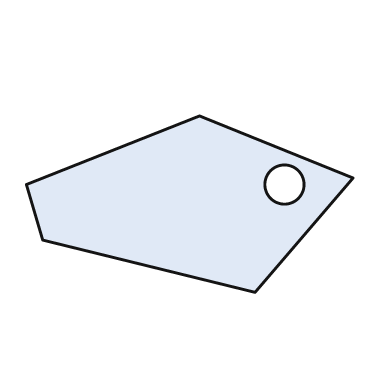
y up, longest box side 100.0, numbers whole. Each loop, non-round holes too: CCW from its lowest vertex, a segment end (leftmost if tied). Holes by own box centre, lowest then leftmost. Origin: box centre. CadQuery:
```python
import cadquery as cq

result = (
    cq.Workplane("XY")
    .moveTo(20.0, -27.0)
    .lineTo(50.0, 8.0)
    .lineTo(3.0, 27.0)
    .lineTo(-50.0, 6.0)
    .lineTo(-45.0, -11.0)
    .close()
    .moveTo(29.0, 6.0)
    .circle(6.0)
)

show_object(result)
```